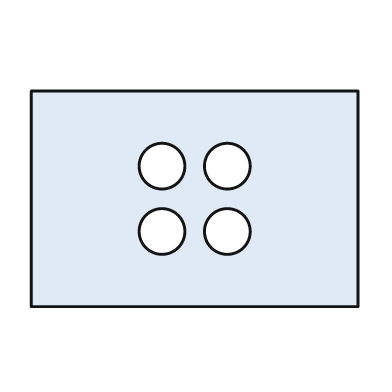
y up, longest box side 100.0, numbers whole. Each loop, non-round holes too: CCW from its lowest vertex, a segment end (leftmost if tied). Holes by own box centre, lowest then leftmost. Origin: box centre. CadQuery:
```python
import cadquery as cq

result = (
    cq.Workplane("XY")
    .moveTo(-50.0, -33.0)
    .lineTo(50.0, -33.0)
    .lineTo(50.0, 33.0)
    .lineTo(-50.0, 33.0)
    .close()
    .moveTo(-10.0, -10.0)
    .circle(7.0)
    .moveTo(10.0, -10.0)
    .circle(7.0)
    .moveTo(-10.0, 10.0)
    .circle(7.0)
    .moveTo(10.0, 10.0)
    .circle(7.0)
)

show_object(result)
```